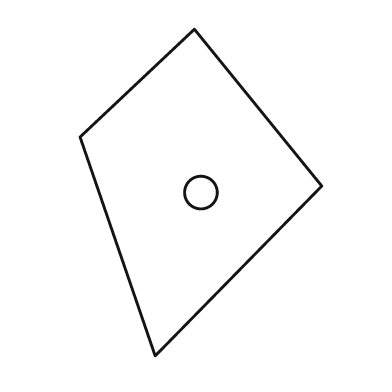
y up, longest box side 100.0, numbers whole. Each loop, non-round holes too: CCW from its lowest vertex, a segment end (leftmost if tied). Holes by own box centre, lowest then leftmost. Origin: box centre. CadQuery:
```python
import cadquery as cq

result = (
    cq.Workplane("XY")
    .moveTo(-14.0, -50.0)
    .lineTo(37.0, 2.0)
    .lineTo(-2.0, 50.0)
    .lineTo(-37.0, 17.0)
    .close()
    .moveTo(0.0, 0.0)
    .circle(5.0)
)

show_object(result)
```